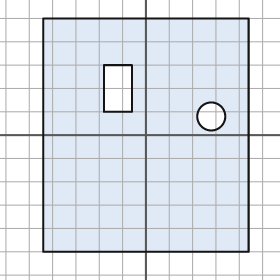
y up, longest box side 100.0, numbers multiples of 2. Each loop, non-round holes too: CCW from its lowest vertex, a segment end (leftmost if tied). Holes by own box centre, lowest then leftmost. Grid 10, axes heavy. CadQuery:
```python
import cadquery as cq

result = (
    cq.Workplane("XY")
    .moveTo(-44.0, -50.0)
    .lineTo(44.0, -50.0)
    .lineTo(44.0, 50.0)
    .lineTo(-44.0, 50.0)
    .close()
    .moveTo(28.0, 8.0)
    .circle(6.0)
    .moveTo(-18.0, 10.0)
    .lineTo(-6.0, 10.0)
    .lineTo(-6.0, 30.0)
    .lineTo(-18.0, 30.0)
    .close()
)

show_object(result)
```